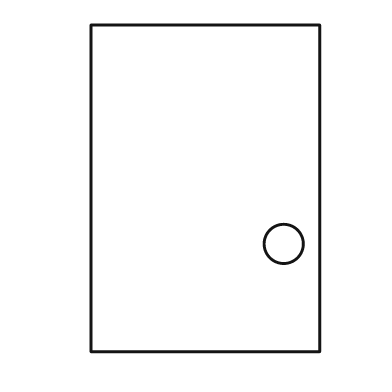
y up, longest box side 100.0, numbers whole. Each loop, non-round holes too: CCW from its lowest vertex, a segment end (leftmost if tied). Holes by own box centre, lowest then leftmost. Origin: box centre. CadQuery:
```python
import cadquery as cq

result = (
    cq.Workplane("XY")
    .moveTo(-35.0, -50.0)
    .lineTo(35.0, -50.0)
    .lineTo(35.0, 50.0)
    .lineTo(-35.0, 50.0)
    .close()
    .moveTo(24.0, -17.0)
    .circle(6.0)
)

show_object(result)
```